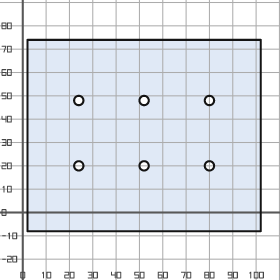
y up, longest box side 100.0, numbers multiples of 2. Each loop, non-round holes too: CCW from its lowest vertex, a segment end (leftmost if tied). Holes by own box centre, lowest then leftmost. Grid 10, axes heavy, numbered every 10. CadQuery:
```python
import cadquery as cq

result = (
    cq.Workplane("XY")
    .moveTo(2.0, -8.0)
    .lineTo(102.0, -8.0)
    .lineTo(102.0, 74.0)
    .lineTo(2.0, 74.0)
    .close()
    .moveTo(24.0, 20.0)
    .circle(2.0)
    .moveTo(52.0, 20.0)
    .circle(2.0)
    .moveTo(80.0, 20.0)
    .circle(2.0)
    .moveTo(24.0, 48.0)
    .circle(2.0)
    .moveTo(52.0, 48.0)
    .circle(2.0)
    .moveTo(80.0, 48.0)
    .circle(2.0)
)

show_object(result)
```